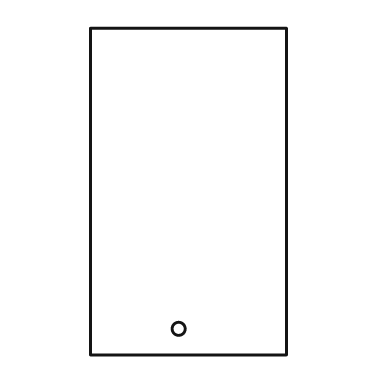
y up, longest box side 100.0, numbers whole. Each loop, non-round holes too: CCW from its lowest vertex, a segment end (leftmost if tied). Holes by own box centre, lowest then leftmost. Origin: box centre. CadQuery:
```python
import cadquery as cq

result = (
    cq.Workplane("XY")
    .moveTo(-30.0, -50.0)
    .lineTo(30.0, -50.0)
    .lineTo(30.0, 50.0)
    .lineTo(-30.0, 50.0)
    .close()
    .moveTo(-3.0, -42.0)
    .circle(2.0)
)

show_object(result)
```